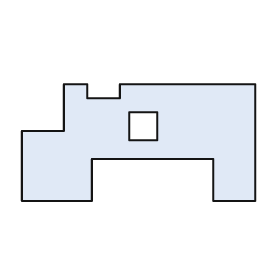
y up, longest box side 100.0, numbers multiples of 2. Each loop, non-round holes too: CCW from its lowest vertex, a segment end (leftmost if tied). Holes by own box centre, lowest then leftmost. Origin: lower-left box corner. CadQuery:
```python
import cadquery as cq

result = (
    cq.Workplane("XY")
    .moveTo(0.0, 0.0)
    .lineTo(30.0, 0.0)
    .lineTo(30.0, 18.0)
    .lineTo(82.0, 18.0)
    .lineTo(82.0, 0.0)
    .lineTo(100.0, 0.0)
    .lineTo(100.0, 50.0)
    .lineTo(42.0, 50.0)
    .lineTo(42.0, 44.0)
    .lineTo(28.0, 44.0)
    .lineTo(28.0, 50.0)
    .lineTo(18.0, 50.0)
    .lineTo(18.0, 30.0)
    .lineTo(0.0, 30.0)
    .close()
    .moveTo(46.0, 26.0)
    .lineTo(58.0, 26.0)
    .lineTo(58.0, 38.0)
    .lineTo(46.0, 38.0)
    .close()
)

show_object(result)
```